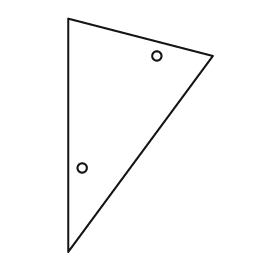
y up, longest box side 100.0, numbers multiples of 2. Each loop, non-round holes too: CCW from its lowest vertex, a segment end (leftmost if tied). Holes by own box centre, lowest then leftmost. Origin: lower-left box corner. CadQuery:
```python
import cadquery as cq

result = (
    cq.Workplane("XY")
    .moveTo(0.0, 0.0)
    .lineTo(62.0, 84.0)
    .lineTo(0.0, 100.0)
    .close()
    .moveTo(6.0, 36.0)
    .circle(2.0)
    .moveTo(38.0, 84.0)
    .circle(2.0)
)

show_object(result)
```